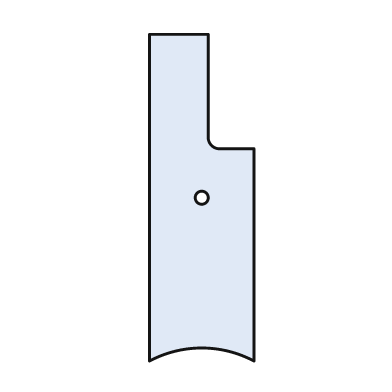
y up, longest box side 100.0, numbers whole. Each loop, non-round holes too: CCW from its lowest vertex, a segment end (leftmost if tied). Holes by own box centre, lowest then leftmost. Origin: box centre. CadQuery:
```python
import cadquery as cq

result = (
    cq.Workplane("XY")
    .moveTo(-16.0, -50.0)
    .threePointArc((0.0, -46.0), (16.0, -50.0))
    .lineTo(16.0, 15.0)
    .lineTo(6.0, 15.0)
    .threePointArc((3.0, 16.0), (2.0, 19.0))
    .lineTo(2.0, 50.0)
    .lineTo(-16.0, 50.0)
    .close()
    .moveTo(0.0, 0.0)
    .circle(2.0)
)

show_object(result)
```